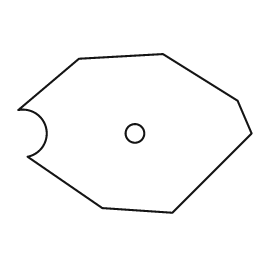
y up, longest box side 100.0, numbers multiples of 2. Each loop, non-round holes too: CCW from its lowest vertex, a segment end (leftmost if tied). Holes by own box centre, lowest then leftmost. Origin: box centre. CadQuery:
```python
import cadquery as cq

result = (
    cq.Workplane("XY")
    .moveTo(16.0, -34.0)
    .lineTo(50.0, 0.0)
    .lineTo(44.0, 14.0)
    .lineTo(12.0, 34.0)
    .lineTo(-24.0, 32.0)
    .lineTo(-50.0, 10.0)
    .threePointArc((-38.0, 2.0), (-46.0, -10.0))
    .lineTo(-14.0, -32.0)
    .close()
    .moveTo(0.0, 0.0)
    .circle(4.0)
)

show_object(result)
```